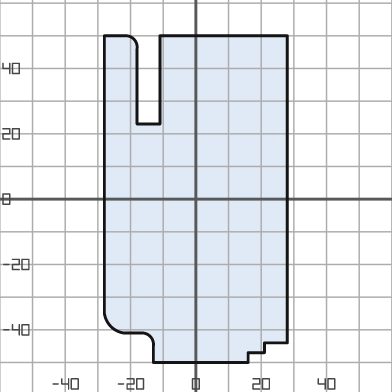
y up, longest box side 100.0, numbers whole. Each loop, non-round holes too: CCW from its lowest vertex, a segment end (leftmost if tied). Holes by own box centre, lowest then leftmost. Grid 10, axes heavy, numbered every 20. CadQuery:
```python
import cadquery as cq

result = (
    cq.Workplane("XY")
    .moveTo(-13.0, -50.0)
    .lineTo(16.0, -50.0)
    .lineTo(16.0, -47.0)
    .lineTo(21.0, -47.0)
    .lineTo(21.0, -44.0)
    .lineTo(28.0, -44.0)
    .lineTo(28.0, 50.0)
    .lineTo(-11.0, 50.0)
    .lineTo(-11.0, 23.0)
    .lineTo(-18.0, 23.0)
    .lineTo(-18.0, 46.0)
    .threePointArc((-19.0, 49.0), (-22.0, 50.0))
    .lineTo(-28.0, 50.0)
    .lineTo(-28.0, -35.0)
    .threePointArc((-26.0, -39.0), (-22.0, -41.0))
    .lineTo(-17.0, -41.0)
    .threePointArc((-14.0, -42.0), (-13.0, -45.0))
    .close()
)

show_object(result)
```